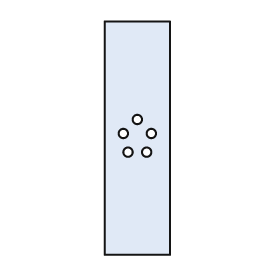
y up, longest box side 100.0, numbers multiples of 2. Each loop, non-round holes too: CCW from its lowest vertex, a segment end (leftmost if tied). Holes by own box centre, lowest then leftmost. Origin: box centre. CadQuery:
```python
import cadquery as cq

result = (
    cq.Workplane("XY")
    .moveTo(-14.0, -50.0)
    .lineTo(14.0, -50.0)
    .lineTo(14.0, 50.0)
    .lineTo(-14.0, 50.0)
    .close()
    .moveTo(-4.0, -6.0)
    .circle(2.0)
    .moveTo(4.0, -6.0)
    .circle(2.0)
    .moveTo(-6.0, 2.0)
    .circle(2.0)
    .moveTo(6.0, 2.0)
    .circle(2.0)
    .moveTo(0.0, 8.0)
    .circle(2.0)
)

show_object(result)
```